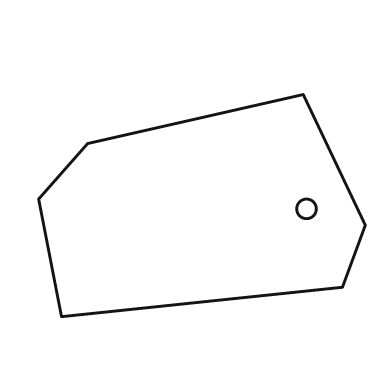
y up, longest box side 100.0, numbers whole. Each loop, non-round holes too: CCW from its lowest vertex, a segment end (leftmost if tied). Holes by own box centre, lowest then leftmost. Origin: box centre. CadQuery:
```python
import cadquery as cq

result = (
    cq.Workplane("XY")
    .moveTo(-43.0, -34.0)
    .lineTo(43.0, -25.0)
    .lineTo(50.0, -6.0)
    .lineTo(31.0, 34.0)
    .lineTo(-35.0, 19.0)
    .lineTo(-50.0, 2.0)
    .close()
    .moveTo(32.0, -1.0)
    .circle(3.0)
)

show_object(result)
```